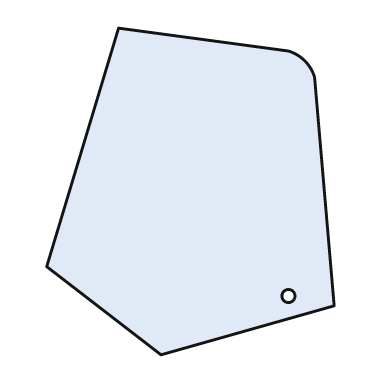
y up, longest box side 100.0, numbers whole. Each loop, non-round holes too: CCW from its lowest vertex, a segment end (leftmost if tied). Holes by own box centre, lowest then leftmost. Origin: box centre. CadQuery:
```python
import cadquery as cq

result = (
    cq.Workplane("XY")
    .moveTo(-9.0, -50.0)
    .lineTo(44.0, -35.0)
    .lineTo(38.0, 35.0)
    .threePointArc((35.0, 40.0), (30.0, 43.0))
    .lineTo(-22.0, 50.0)
    .lineTo(-44.0, -23.0)
    .close()
    .moveTo(30.0, -32.0)
    .circle(2.0)
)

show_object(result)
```